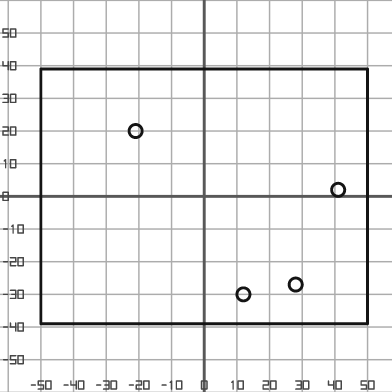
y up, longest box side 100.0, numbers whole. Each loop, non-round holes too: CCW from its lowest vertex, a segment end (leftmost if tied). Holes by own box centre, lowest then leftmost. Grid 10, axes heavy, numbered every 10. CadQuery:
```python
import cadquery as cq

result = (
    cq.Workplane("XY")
    .moveTo(-50.0, -39.0)
    .lineTo(50.0, -39.0)
    .lineTo(50.0, 39.0)
    .lineTo(-50.0, 39.0)
    .close()
    .moveTo(12.0, -30.0)
    .circle(2.0)
    .moveTo(28.0, -27.0)
    .circle(2.0)
    .moveTo(41.0, 2.0)
    .circle(2.0)
    .moveTo(-21.0, 20.0)
    .circle(2.0)
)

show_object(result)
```